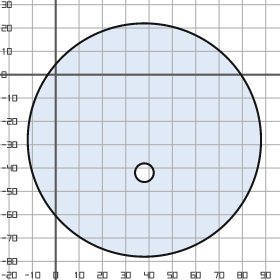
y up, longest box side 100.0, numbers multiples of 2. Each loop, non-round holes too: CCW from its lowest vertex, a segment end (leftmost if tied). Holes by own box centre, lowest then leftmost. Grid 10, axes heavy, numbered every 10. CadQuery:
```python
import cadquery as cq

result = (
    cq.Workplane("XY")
    .moveTo(38.0, -28.0)
    .circle(50.0)
    .moveTo(38.0, -42.0)
    .circle(4.0)
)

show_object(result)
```